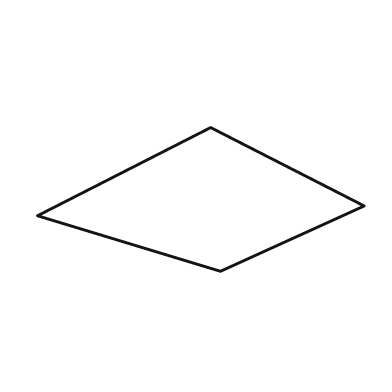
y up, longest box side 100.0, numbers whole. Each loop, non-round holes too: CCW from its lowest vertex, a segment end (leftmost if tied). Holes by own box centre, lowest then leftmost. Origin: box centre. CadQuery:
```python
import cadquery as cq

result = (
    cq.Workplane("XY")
    .moveTo(6.0, -22.0)
    .lineTo(50.0, -2.0)
    .lineTo(3.0, 22.0)
    .lineTo(-50.0, -5.0)
    .close()
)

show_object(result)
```